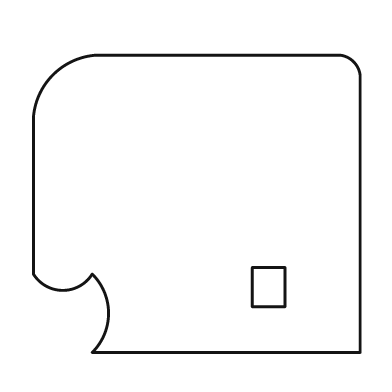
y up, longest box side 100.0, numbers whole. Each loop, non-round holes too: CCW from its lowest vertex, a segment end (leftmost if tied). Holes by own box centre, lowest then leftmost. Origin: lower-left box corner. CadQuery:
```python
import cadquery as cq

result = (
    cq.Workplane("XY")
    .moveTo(18.0, 0.0)
    .lineTo(100.0, 0.0)
    .lineTo(100.0, 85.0)
    .threePointArc((98.0, 89.0), (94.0, 91.0))
    .lineTo(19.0, 91.0)
    .threePointArc((6.0, 85.0), (0.0, 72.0))
    .lineTo(0.0, 24.0)
    .threePointArc((9.0, 19.0), (18.0, 24.0))
    .threePointArc((23.0, 12.0), (18.0, 0.0))
    .close()
    .moveTo(67.0, 14.0)
    .lineTo(77.0, 14.0)
    .lineTo(77.0, 26.0)
    .lineTo(67.0, 26.0)
    .close()
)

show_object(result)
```